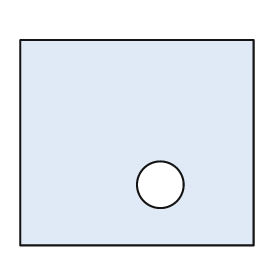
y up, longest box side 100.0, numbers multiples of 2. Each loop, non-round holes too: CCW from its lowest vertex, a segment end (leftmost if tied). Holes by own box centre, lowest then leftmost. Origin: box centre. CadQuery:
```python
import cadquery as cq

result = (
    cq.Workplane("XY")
    .moveTo(-50.0, -44.0)
    .lineTo(50.0, -44.0)
    .lineTo(50.0, 44.0)
    .lineTo(-50.0, 44.0)
    .close()
    .moveTo(10.0, -18.0)
    .circle(10.0)
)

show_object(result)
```